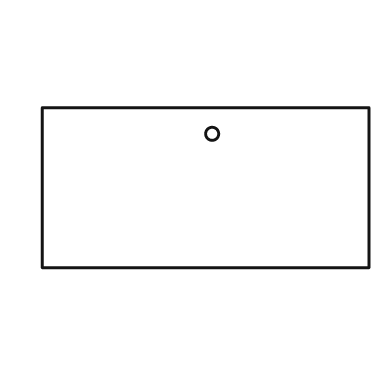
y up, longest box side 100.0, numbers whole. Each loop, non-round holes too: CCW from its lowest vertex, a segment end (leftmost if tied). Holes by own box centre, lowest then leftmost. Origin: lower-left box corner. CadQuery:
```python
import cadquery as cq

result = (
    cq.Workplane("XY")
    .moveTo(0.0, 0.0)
    .lineTo(100.0, 0.0)
    .lineTo(100.0, 49.0)
    .lineTo(0.0, 49.0)
    .close()
    .moveTo(52.0, 41.0)
    .circle(2.0)
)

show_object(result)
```